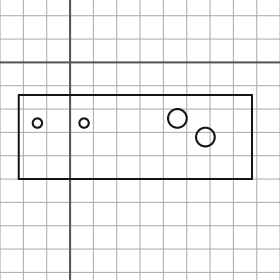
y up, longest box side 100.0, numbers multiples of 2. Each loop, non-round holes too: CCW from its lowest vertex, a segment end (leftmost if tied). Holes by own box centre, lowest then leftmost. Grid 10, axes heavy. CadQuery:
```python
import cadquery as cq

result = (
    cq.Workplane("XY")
    .moveTo(-22.0, -50.0)
    .lineTo(78.0, -50.0)
    .lineTo(78.0, -14.0)
    .lineTo(-22.0, -14.0)
    .close()
    .moveTo(58.0, -32.0)
    .circle(4.0)
    .moveTo(-14.0, -26.0)
    .circle(2.0)
    .moveTo(6.0, -26.0)
    .circle(2.0)
    .moveTo(46.0, -24.0)
    .circle(4.0)
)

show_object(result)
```